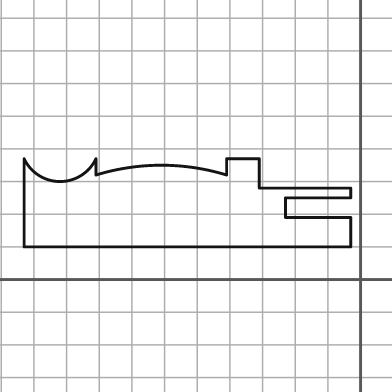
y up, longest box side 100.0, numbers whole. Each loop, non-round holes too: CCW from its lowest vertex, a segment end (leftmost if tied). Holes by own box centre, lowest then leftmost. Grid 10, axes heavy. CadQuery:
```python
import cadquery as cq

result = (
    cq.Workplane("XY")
    .moveTo(-103.0, 10.0)
    .lineTo(-3.0, 10.0)
    .lineTo(-3.0, 19.0)
    .lineTo(-23.0, 19.0)
    .lineTo(-23.0, 25.0)
    .lineTo(-3.0, 25.0)
    .lineTo(-3.0, 28.0)
    .lineTo(-31.0, 28.0)
    .lineTo(-31.0, 37.0)
    .lineTo(-41.0, 37.0)
    .lineTo(-41.0, 32.0)
    .threePointArc((-61.0, 35.0), (-81.0, 32.0))
    .lineTo(-81.0, 37.0)
    .threePointArc((-92.0, 30.0), (-103.0, 37.0))
    .close()
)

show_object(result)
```